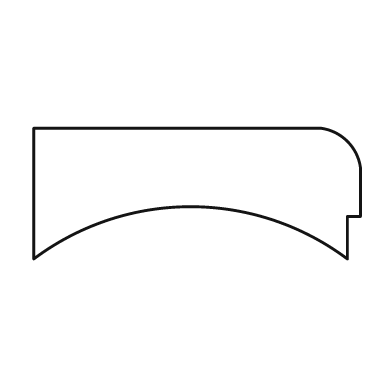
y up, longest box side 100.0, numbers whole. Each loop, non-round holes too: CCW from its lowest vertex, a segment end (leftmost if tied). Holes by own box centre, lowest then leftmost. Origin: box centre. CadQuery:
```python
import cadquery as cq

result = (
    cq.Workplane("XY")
    .moveTo(-50.0, -20.0)
    .threePointArc((-2.0, -4.0), (46.0, -20.0))
    .lineTo(46.0, -7.0)
    .lineTo(50.0, -7.0)
    .lineTo(50.0, 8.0)
    .threePointArc((46.0, 16.0), (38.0, 20.0))
    .lineTo(-50.0, 20.0)
    .close()
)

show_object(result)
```